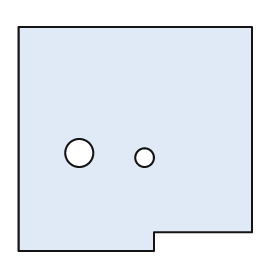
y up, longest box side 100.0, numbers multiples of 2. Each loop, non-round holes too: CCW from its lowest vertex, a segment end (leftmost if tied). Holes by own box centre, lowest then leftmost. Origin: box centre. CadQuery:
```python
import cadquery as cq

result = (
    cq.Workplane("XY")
    .moveTo(-50.0, -48.0)
    .lineTo(8.0, -48.0)
    .lineTo(8.0, -40.0)
    .lineTo(50.0, -40.0)
    .lineTo(50.0, 48.0)
    .lineTo(-50.0, 48.0)
    .close()
    .moveTo(4.0, -8.0)
    .circle(4.0)
    .moveTo(-24.0, -6.0)
    .circle(6.0)
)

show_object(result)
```